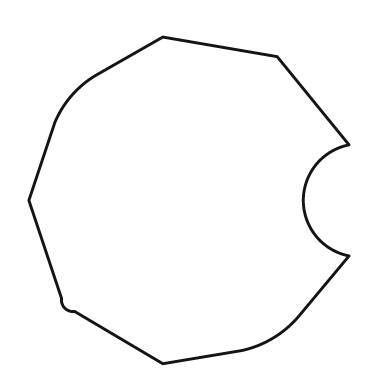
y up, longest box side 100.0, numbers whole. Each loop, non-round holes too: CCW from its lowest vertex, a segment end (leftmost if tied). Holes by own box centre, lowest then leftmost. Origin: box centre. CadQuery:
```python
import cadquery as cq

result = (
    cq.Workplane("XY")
    .moveTo(-8.0, -50.0)
    .lineTo(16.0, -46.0)
    .threePointArc((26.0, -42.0), (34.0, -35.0))
    .lineTo(49.0, -17.0)
    .threePointArc((35.0, 0.0), (49.0, 17.0))
    .lineTo(27.0, 44.0)
    .lineTo(-8.0, 50.0)
    .lineTo(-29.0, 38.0)
    .threePointArc((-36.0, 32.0), (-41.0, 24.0))
    .lineTo(-49.0, 0.0)
    .lineTo(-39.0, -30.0)
    .threePointArc((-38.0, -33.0), (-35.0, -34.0))
    .close()
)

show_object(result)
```